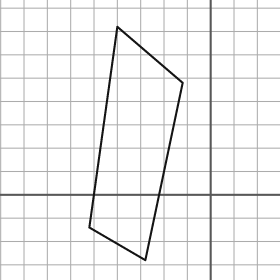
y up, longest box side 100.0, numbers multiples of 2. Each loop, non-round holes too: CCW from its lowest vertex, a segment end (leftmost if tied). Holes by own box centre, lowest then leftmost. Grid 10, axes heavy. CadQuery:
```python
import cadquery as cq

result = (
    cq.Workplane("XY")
    .moveTo(-28.0, -28.0)
    .lineTo(-12.0, 48.0)
    .lineTo(-40.0, 72.0)
    .lineTo(-52.0, -14.0)
    .close()
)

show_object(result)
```